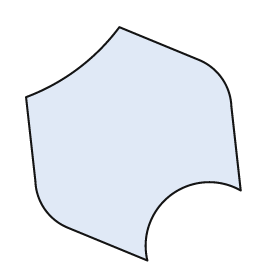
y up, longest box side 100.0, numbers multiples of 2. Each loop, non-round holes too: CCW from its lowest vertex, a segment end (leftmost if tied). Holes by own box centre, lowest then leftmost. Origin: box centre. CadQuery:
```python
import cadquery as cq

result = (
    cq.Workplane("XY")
    .moveTo(6.0, -50.0)
    .threePointArc((16.0, -22.0), (46.0, -20.0))
    .lineTo(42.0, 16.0)
    .threePointArc((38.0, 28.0), (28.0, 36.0))
    .lineTo(-6.0, 50.0)
    .threePointArc((-24.0, 32.0), (-46.0, 20.0))
    .lineTo(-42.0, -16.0)
    .threePointArc((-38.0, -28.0), (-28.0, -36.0))
    .close()
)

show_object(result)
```